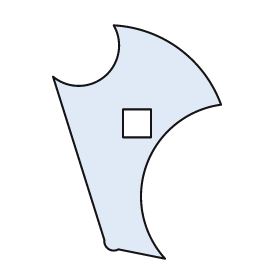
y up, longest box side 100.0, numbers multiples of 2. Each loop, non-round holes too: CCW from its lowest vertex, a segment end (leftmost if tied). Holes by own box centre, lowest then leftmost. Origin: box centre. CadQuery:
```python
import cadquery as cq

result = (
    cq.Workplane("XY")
    .moveTo(12.0, -50.0)
    .threePointArc((4.0, -10.0), (36.0, 16.0))
    .threePointArc((18.0, 40.0), (-10.0, 50.0))
    .threePointArc((-14.0, 28.0), (-36.0, 28.0))
    .lineTo(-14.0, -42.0)
    .threePointArc((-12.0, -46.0), (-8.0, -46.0))
    .close()
    .moveTo(-6.0, 2.0)
    .lineTo(6.0, 2.0)
    .lineTo(6.0, 14.0)
    .lineTo(-6.0, 14.0)
    .close()
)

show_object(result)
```